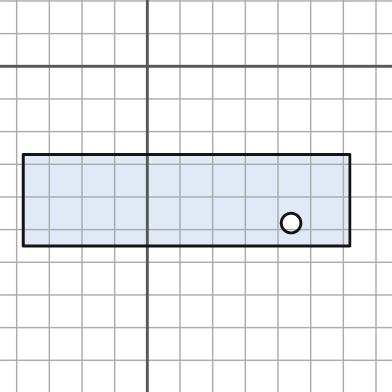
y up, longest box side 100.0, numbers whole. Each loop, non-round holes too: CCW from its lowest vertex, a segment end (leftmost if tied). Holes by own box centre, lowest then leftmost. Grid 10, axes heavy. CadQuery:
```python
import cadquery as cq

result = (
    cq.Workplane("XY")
    .moveTo(-38.0, -55.0)
    .lineTo(62.0, -55.0)
    .lineTo(62.0, -27.0)
    .lineTo(-38.0, -27.0)
    .close()
    .moveTo(44.0, -48.0)
    .circle(3.0)
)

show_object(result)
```